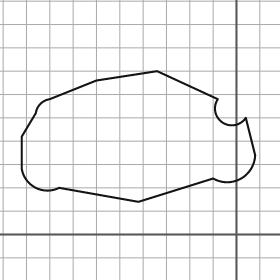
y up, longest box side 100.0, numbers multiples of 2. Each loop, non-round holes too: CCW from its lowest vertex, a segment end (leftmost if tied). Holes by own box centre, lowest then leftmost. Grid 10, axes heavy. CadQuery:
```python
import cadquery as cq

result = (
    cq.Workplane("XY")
    .moveTo(-42.0, 14.0)
    .lineTo(-10.0, 24.0)
    .threePointArc((2.0, 24.0), (8.0, 34.0))
    .lineTo(4.0, 50.0)
    .threePointArc((-6.0, 48.0), (-8.0, 58.0))
    .lineTo(-34.0, 70.0)
    .lineTo(-60.0, 66.0)
    .lineTo(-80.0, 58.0)
    .threePointArc((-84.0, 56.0), (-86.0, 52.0))
    .lineTo(-92.0, 42.0)
    .lineTo(-92.0, 28.0)
    .threePointArc((-86.0, 20.0), (-76.0, 20.0))
    .close()
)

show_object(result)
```